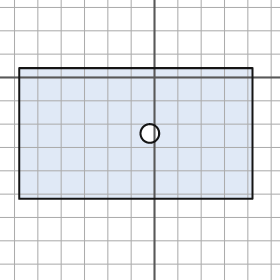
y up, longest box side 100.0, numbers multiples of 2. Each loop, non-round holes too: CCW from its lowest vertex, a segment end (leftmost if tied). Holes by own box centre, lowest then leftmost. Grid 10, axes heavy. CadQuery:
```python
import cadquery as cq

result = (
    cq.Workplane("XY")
    .moveTo(-58.0, -52.0)
    .lineTo(42.0, -52.0)
    .lineTo(42.0, 4.0)
    .lineTo(-58.0, 4.0)
    .close()
    .moveTo(-2.0, -24.0)
    .circle(4.0)
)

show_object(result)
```